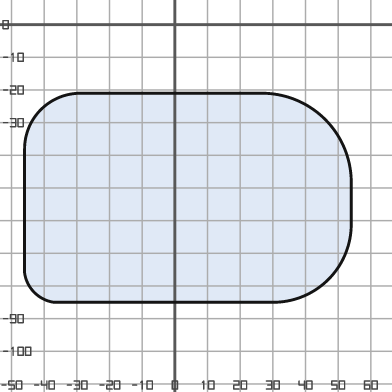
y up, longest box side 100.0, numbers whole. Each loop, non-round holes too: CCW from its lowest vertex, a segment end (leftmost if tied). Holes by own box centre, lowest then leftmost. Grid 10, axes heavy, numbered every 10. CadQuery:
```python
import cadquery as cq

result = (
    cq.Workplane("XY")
    .moveTo(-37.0, -85.0)
    .lineTo(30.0, -85.0)
    .threePointArc((47.0, -78.0), (54.0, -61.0))
    .lineTo(54.0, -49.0)
    .threePointArc((46.0, -29.0), (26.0, -21.0))
    .lineTo(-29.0, -21.0)
    .threePointArc((-41.0, -26.0), (-46.0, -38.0))
    .lineTo(-46.0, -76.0)
    .threePointArc((-43.0, -82.0), (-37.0, -85.0))
    .close()
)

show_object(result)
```